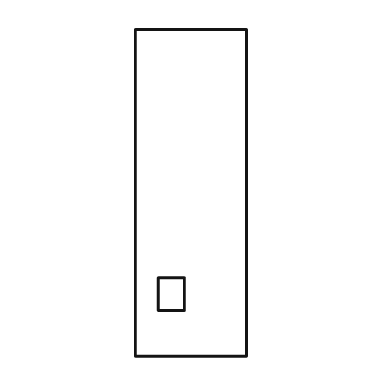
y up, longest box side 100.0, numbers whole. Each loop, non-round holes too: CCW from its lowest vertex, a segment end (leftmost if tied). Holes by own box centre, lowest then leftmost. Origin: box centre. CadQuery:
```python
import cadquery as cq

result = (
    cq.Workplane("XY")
    .moveTo(-17.0, -50.0)
    .lineTo(17.0, -50.0)
    .lineTo(17.0, 50.0)
    .lineTo(-17.0, 50.0)
    .close()
    .moveTo(-10.0, -36.0)
    .lineTo(-2.0, -36.0)
    .lineTo(-2.0, -26.0)
    .lineTo(-10.0, -26.0)
    .close()
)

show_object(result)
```